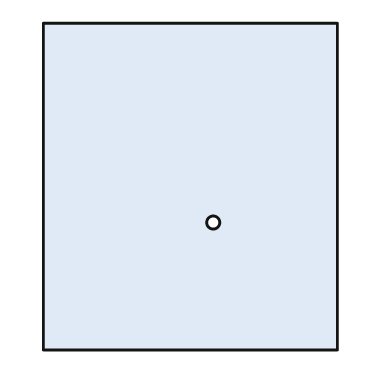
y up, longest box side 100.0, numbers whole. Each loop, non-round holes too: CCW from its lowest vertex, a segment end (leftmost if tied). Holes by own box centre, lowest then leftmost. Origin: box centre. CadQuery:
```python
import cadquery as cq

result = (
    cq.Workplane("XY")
    .moveTo(-45.0, -50.0)
    .lineTo(45.0, -50.0)
    .lineTo(45.0, 50.0)
    .lineTo(-45.0, 50.0)
    .close()
    .moveTo(7.0, -11.0)
    .circle(2.0)
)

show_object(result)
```